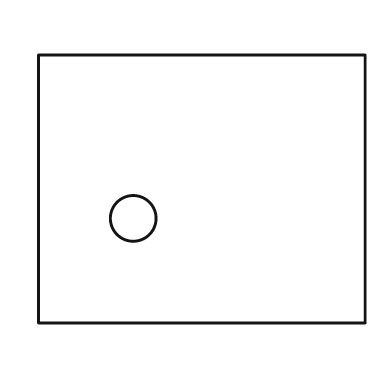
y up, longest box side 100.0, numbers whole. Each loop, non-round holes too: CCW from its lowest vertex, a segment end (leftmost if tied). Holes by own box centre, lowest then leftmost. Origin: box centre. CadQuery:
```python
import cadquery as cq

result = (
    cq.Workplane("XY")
    .moveTo(-50.0, -41.0)
    .lineTo(50.0, -41.0)
    .lineTo(50.0, 41.0)
    .lineTo(-50.0, 41.0)
    .close()
    .moveTo(-21.0, -9.0)
    .circle(7.0)
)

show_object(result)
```